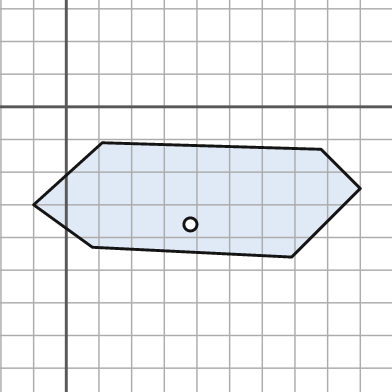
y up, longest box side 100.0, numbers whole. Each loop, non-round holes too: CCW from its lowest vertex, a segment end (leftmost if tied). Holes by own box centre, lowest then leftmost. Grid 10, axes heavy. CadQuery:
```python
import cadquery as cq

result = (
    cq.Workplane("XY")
    .moveTo(69.0, -46.0)
    .lineTo(90.0, -25.0)
    .lineTo(78.0, -13.0)
    .lineTo(11.0, -11.0)
    .lineTo(-10.0, -30.0)
    .lineTo(8.0, -43.0)
    .close()
    .moveTo(38.0, -36.0)
    .circle(2.0)
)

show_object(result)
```